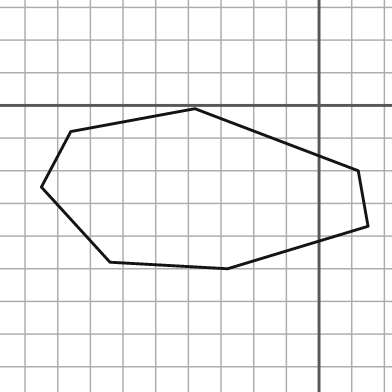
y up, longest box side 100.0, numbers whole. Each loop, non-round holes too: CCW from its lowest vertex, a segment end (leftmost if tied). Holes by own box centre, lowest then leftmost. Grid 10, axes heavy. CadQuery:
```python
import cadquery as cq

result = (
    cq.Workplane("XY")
    .moveTo(-28.0, -50.0)
    .lineTo(15.0, -37.0)
    .lineTo(12.0, -20.0)
    .lineTo(-38.0, -1.0)
    .lineTo(-76.0, -8.0)
    .lineTo(-85.0, -25.0)
    .lineTo(-64.0, -48.0)
    .close()
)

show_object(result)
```